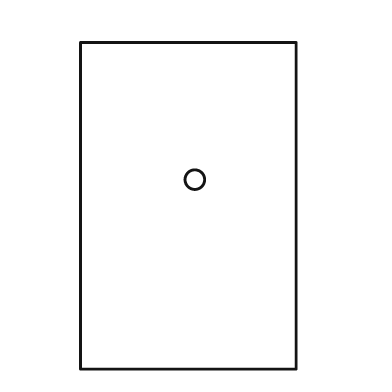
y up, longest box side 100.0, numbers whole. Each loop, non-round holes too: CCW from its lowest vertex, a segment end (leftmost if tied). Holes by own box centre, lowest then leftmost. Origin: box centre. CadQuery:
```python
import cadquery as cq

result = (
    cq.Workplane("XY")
    .moveTo(-33.0, -50.0)
    .lineTo(33.0, -50.0)
    .lineTo(33.0, 50.0)
    .lineTo(-33.0, 50.0)
    .close()
    .moveTo(2.0, 8.0)
    .circle(3.0)
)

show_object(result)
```